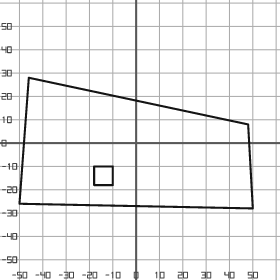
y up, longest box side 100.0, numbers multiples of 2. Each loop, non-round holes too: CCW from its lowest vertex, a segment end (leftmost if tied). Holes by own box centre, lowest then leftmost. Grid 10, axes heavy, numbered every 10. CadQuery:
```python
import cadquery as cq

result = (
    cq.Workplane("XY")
    .moveTo(50.0, -28.0)
    .lineTo(48.0, 8.0)
    .lineTo(-46.0, 28.0)
    .lineTo(-50.0, -26.0)
    .close()
    .moveTo(-18.0, -18.0)
    .lineTo(-10.0, -18.0)
    .lineTo(-10.0, -10.0)
    .lineTo(-18.0, -10.0)
    .close()
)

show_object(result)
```